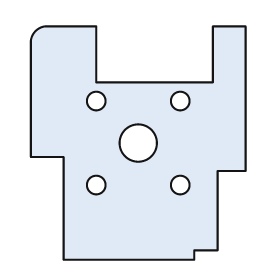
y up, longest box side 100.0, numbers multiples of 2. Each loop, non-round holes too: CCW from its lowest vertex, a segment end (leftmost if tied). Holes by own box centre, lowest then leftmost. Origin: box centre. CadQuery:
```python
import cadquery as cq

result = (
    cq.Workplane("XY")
    .moveTo(-32.0, -50.0)
    .lineTo(24.0, -50.0)
    .lineTo(24.0, -46.0)
    .lineTo(34.0, -46.0)
    .lineTo(34.0, -12.0)
    .lineTo(46.0, -12.0)
    .lineTo(46.0, 50.0)
    .lineTo(32.0, 50.0)
    .lineTo(32.0, 26.0)
    .lineTo(-18.0, 26.0)
    .lineTo(-18.0, 50.0)
    .lineTo(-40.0, 50.0)
    .threePointArc((-44.0, 48.0), (-46.0, 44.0))
    .lineTo(-46.0, -6.0)
    .lineTo(-32.0, -6.0)
    .close()
    .moveTo(-18.0, -18.0)
    .circle(4.0)
    .moveTo(18.0, -18.0)
    .circle(4.0)
    .moveTo(0.0, 0.0)
    .circle(8.0)
    .moveTo(-18.0, 18.0)
    .circle(4.0)
    .moveTo(18.0, 18.0)
    .circle(4.0)
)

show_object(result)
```